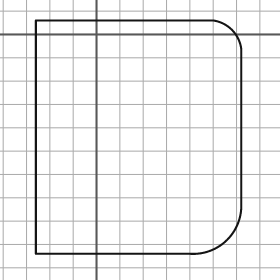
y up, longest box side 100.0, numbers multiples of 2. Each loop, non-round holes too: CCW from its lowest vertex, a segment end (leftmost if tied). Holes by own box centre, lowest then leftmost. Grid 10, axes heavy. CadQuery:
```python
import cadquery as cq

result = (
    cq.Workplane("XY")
    .moveTo(-26.0, -94.0)
    .lineTo(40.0, -94.0)
    .threePointArc((56.0, -88.0), (62.0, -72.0))
    .lineTo(62.0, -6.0)
    .threePointArc((58.0, 2.0), (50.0, 6.0))
    .lineTo(-26.0, 6.0)
    .close()
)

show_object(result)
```